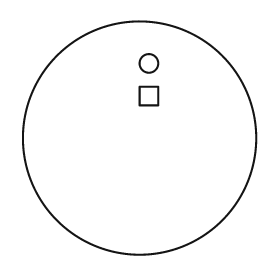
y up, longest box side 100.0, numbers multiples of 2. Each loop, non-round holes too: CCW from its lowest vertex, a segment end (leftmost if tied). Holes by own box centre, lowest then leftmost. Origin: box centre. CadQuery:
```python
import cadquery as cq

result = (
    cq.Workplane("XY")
    .moveTo(0.0, 0.0)
    .circle(50.0)
    .moveTo(0.0, 14.0)
    .lineTo(8.0, 14.0)
    .lineTo(8.0, 22.0)
    .lineTo(0.0, 22.0)
    .close()
    .moveTo(4.0, 32.0)
    .circle(4.0)
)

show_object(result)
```